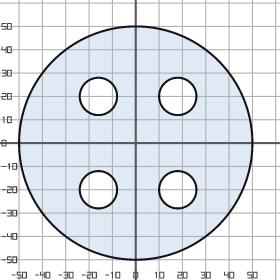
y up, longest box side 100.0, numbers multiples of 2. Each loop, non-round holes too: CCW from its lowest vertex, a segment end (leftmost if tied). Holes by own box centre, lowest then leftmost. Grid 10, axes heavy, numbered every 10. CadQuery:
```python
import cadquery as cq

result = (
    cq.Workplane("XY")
    .moveTo(0.0, 0.0)
    .circle(50.0)
    .moveTo(-16.0, -20.0)
    .circle(8.0)
    .moveTo(18.0, -20.0)
    .circle(8.0)
    .moveTo(-16.0, 20.0)
    .circle(8.0)
    .moveTo(18.0, 20.0)
    .circle(8.0)
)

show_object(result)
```